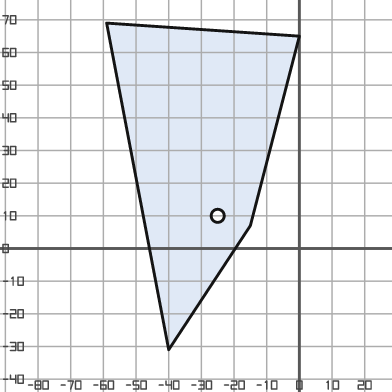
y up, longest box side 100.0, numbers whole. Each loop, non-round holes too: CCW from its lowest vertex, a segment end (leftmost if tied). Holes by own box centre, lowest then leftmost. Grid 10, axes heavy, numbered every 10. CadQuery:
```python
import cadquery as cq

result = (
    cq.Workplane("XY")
    .moveTo(-40.0, -31.0)
    .lineTo(-15.0, 7.0)
    .lineTo(0.0, 65.0)
    .lineTo(-59.0, 69.0)
    .close()
    .moveTo(-25.0, 10.0)
    .circle(2.0)
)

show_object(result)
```